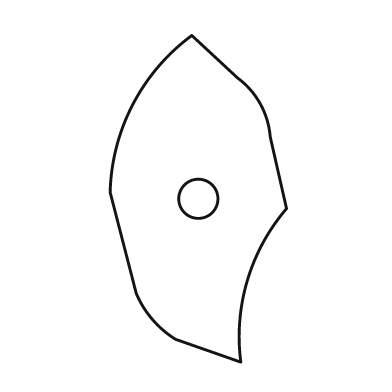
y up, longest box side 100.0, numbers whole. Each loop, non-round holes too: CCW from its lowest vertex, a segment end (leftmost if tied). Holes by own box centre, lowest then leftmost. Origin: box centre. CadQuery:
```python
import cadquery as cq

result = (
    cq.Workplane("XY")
    .moveTo(13.0, -50.0)
    .threePointArc((15.0, -25.0), (27.0, -3.0))
    .lineTo(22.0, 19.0)
    .threePointArc((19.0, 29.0), (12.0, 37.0))
    .lineTo(-2.0, 50.0)
    .threePointArc((-20.0, 29.0), (-27.0, 2.0))
    .lineTo(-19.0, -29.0)
    .threePointArc((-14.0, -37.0), (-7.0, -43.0))
    .close()
    .moveTo(0.0, 0.0)
    .circle(6.0)
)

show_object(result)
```